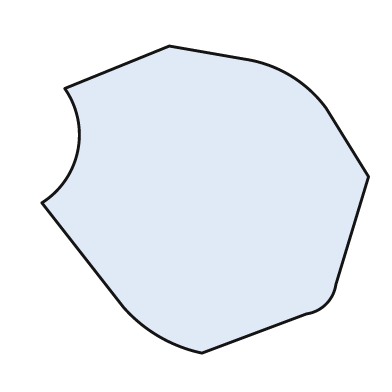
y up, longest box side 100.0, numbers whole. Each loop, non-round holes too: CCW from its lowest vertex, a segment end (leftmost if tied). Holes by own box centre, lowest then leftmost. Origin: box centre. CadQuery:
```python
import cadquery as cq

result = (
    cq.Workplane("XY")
    .moveTo(-1.0, -47.0)
    .lineTo(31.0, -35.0)
    .threePointArc((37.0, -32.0), (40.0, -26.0))
    .lineTo(50.0, 7.0)
    .lineTo(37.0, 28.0)
    .threePointArc((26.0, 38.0), (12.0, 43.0))
    .lineTo(-11.0, 47.0)
    .lineTo(-43.0, 34.0)
    .threePointArc((-39.0, 15.0), (-50.0, -1.0))
    .lineTo(-25.0, -33.0)
    .threePointArc((-14.0, -42.0), (-1.0, -47.0))
    .close()
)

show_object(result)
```